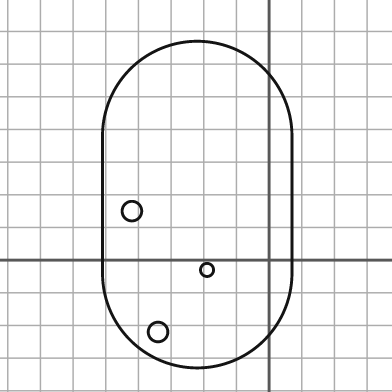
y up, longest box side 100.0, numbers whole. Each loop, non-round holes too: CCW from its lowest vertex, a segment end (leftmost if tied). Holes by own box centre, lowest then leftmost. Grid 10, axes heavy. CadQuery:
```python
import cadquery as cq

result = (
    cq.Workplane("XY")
    .moveTo(-51.0, -4.0)
    .threePointArc((-22.0, -33.0), (7.0, -4.0))
    .lineTo(7.0, 38.0)
    .threePointArc((-22.0, 67.0), (-51.0, 38.0))
    .close()
    .moveTo(-34.0, -22.0)
    .circle(3.0)
    .moveTo(-19.0, -3.0)
    .circle(2.0)
    .moveTo(-42.0, 15.0)
    .circle(3.0)
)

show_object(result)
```